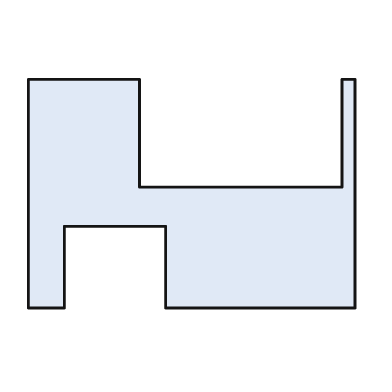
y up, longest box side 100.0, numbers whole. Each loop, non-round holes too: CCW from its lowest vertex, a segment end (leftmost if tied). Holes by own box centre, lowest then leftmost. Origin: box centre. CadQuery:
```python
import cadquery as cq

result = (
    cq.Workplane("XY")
    .moveTo(-50.0, -35.0)
    .lineTo(-39.0, -35.0)
    .lineTo(-39.0, -10.0)
    .lineTo(-8.0, -10.0)
    .lineTo(-8.0, -35.0)
    .lineTo(50.0, -35.0)
    .lineTo(50.0, 35.0)
    .lineTo(46.0, 35.0)
    .lineTo(46.0, 2.0)
    .lineTo(-16.0, 2.0)
    .lineTo(-16.0, 35.0)
    .lineTo(-50.0, 35.0)
    .close()
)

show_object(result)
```